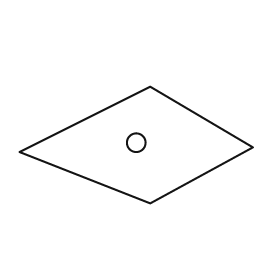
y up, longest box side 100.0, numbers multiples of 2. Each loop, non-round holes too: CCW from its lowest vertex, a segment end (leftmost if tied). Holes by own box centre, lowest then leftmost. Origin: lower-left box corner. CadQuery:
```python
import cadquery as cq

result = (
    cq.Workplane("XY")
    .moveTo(56.0, 0.0)
    .lineTo(100.0, 24.0)
    .lineTo(56.0, 50.0)
    .lineTo(0.0, 22.0)
    .close()
    .moveTo(50.0, 26.0)
    .circle(4.0)
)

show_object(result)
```